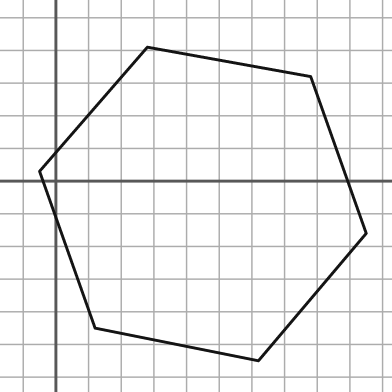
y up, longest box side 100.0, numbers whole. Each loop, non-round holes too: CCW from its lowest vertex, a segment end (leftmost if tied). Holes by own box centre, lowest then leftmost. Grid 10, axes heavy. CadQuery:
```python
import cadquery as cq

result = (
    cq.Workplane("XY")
    .moveTo(62.0, -55.0)
    .lineTo(95.0, -16.0)
    .lineTo(78.0, 32.0)
    .lineTo(28.0, 41.0)
    .lineTo(-5.0, 3.0)
    .lineTo(12.0, -45.0)
    .close()
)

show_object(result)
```